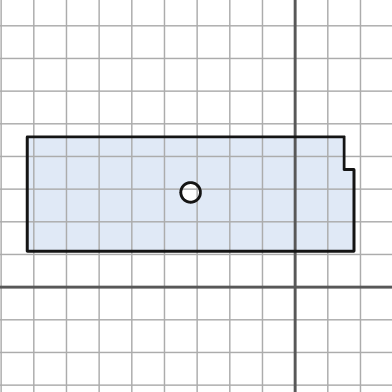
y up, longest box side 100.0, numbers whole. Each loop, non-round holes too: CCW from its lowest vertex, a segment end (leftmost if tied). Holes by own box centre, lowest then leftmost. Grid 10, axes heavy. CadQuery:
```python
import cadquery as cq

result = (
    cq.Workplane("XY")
    .moveTo(-82.0, 11.0)
    .lineTo(18.0, 11.0)
    .lineTo(18.0, 36.0)
    .lineTo(15.0, 36.0)
    .lineTo(15.0, 46.0)
    .lineTo(-82.0, 46.0)
    .close()
    .moveTo(-32.0, 29.0)
    .circle(3.0)
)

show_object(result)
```